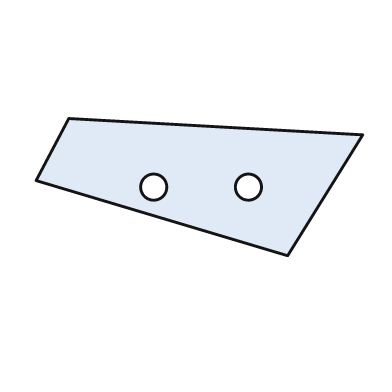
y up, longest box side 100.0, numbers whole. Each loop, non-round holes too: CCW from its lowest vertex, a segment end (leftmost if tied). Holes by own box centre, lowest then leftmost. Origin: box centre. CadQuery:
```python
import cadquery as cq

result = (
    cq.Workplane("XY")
    .moveTo(27.0, -21.0)
    .lineTo(50.0, 16.0)
    .lineTo(-40.0, 21.0)
    .lineTo(-50.0, 2.0)
    .close()
    .moveTo(-14.0, 0.0)
    .circle(4.0)
    .moveTo(15.0, 0.0)
    .circle(4.0)
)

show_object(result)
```